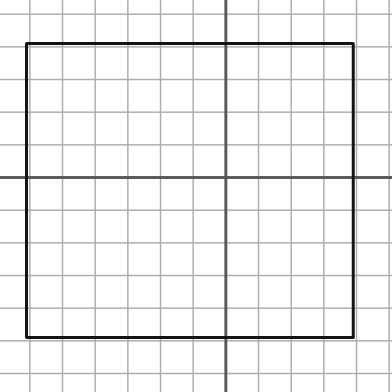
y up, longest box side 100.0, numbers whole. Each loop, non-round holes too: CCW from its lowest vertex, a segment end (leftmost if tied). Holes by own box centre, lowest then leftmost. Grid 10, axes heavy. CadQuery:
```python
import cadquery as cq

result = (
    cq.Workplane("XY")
    .moveTo(-61.0, -49.0)
    .lineTo(39.0, -49.0)
    .lineTo(39.0, 41.0)
    .lineTo(-61.0, 41.0)
    .close()
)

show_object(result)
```